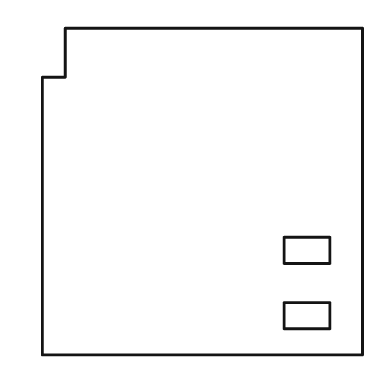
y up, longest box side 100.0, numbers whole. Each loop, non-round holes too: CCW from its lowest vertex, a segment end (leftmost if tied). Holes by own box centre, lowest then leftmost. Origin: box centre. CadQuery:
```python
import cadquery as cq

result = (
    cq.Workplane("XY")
    .moveTo(-49.0, -50.0)
    .lineTo(49.0, -50.0)
    .lineTo(49.0, 50.0)
    .lineTo(-42.0, 50.0)
    .lineTo(-42.0, 35.0)
    .lineTo(-49.0, 35.0)
    .close()
    .moveTo(25.0, -42.0)
    .lineTo(39.0, -42.0)
    .lineTo(39.0, -34.0)
    .lineTo(25.0, -34.0)
    .close()
    .moveTo(25.0, -22.0)
    .lineTo(39.0, -22.0)
    .lineTo(39.0, -14.0)
    .lineTo(25.0, -14.0)
    .close()
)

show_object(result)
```